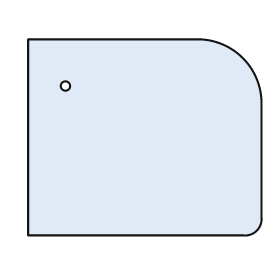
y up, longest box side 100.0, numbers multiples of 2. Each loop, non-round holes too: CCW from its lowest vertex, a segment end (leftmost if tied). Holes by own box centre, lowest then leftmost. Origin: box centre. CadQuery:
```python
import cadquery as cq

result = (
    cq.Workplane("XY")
    .moveTo(-50.0, -42.0)
    .lineTo(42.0, -42.0)
    .threePointArc((48.0, -40.0), (50.0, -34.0))
    .lineTo(50.0, 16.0)
    .threePointArc((42.0, 34.0), (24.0, 42.0))
    .lineTo(-50.0, 42.0)
    .close()
    .moveTo(-34.0, 22.0)
    .circle(2.0)
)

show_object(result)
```